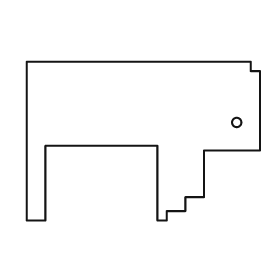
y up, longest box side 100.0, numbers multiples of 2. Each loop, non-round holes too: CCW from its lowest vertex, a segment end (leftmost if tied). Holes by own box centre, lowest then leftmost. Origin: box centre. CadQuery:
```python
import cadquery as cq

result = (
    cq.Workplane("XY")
    .moveTo(-50.0, -34.0)
    .lineTo(-42.0, -34.0)
    .lineTo(-42.0, -2.0)
    .lineTo(6.0, -2.0)
    .lineTo(6.0, -34.0)
    .lineTo(10.0, -34.0)
    .lineTo(10.0, -30.0)
    .lineTo(18.0, -30.0)
    .lineTo(18.0, -24.0)
    .lineTo(26.0, -24.0)
    .lineTo(26.0, -4.0)
    .lineTo(50.0, -4.0)
    .lineTo(50.0, 30.0)
    .lineTo(46.0, 30.0)
    .lineTo(46.0, 34.0)
    .lineTo(-50.0, 34.0)
    .close()
    .moveTo(40.0, 8.0)
    .circle(2.0)
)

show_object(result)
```